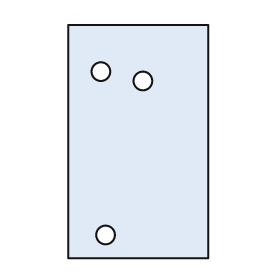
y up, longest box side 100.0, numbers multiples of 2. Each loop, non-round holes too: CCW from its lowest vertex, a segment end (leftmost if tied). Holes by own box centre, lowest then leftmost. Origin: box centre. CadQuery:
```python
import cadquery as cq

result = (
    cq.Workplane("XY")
    .moveTo(-30.0, -50.0)
    .lineTo(30.0, -50.0)
    .lineTo(30.0, 50.0)
    .lineTo(-30.0, 50.0)
    .close()
    .moveTo(-14.0, -40.0)
    .circle(4.0)
    .moveTo(2.0, 26.0)
    .circle(4.0)
    .moveTo(-16.0, 30.0)
    .circle(4.0)
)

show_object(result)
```